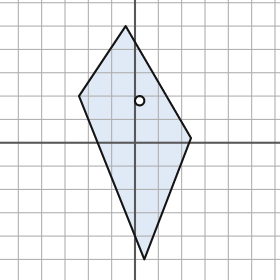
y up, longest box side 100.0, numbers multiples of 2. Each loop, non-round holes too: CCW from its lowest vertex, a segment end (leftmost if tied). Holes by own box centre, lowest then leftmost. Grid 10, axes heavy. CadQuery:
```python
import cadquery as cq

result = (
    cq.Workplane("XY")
    .moveTo(4.0, -50.0)
    .lineTo(24.0, 2.0)
    .lineTo(-4.0, 50.0)
    .lineTo(-24.0, 20.0)
    .close()
    .moveTo(2.0, 18.0)
    .circle(2.0)
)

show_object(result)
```